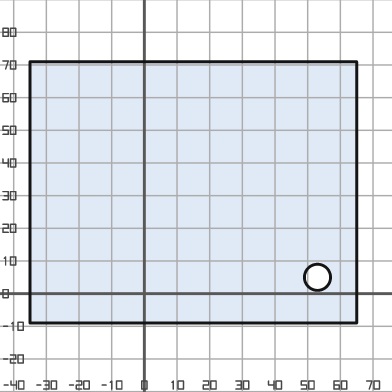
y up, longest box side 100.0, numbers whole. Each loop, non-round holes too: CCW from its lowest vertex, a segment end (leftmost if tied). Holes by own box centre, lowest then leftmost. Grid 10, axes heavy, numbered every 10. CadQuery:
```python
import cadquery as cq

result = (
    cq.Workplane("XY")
    .moveTo(-35.0, -9.0)
    .lineTo(65.0, -9.0)
    .lineTo(65.0, 71.0)
    .lineTo(-35.0, 71.0)
    .close()
    .moveTo(53.0, 5.0)
    .circle(4.0)
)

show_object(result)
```